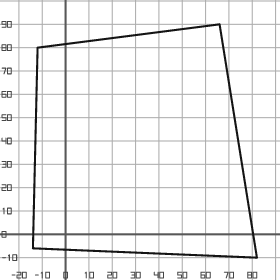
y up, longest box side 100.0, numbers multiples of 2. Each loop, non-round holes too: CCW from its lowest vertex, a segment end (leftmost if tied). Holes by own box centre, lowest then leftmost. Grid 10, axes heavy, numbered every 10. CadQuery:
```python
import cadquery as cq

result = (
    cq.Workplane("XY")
    .moveTo(82.0, -10.0)
    .lineTo(66.0, 90.0)
    .lineTo(-12.0, 80.0)
    .lineTo(-14.0, -6.0)
    .close()
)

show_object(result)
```